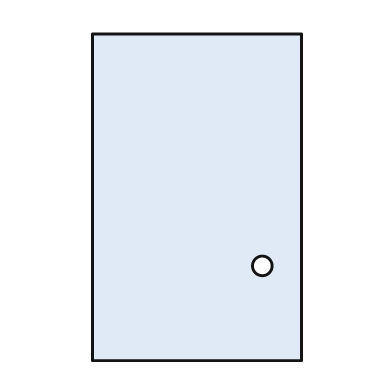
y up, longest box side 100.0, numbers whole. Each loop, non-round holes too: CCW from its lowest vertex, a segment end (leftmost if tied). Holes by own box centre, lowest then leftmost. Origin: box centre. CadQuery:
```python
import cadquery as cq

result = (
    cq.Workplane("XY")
    .moveTo(-32.0, -50.0)
    .lineTo(32.0, -50.0)
    .lineTo(32.0, 50.0)
    .lineTo(-32.0, 50.0)
    .close()
    .moveTo(20.0, -21.0)
    .circle(3.0)
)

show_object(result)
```